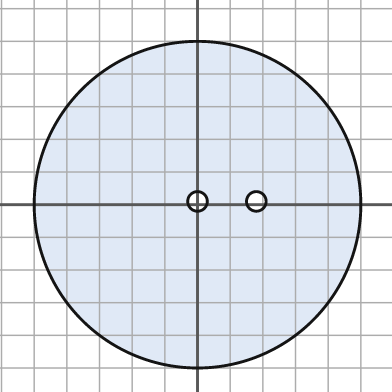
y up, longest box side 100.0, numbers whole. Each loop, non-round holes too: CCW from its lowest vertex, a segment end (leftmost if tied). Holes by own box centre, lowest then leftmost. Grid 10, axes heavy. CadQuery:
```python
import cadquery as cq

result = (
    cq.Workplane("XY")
    .moveTo(0.0, 0.0)
    .circle(50.0)
    .moveTo(0.0, 1.0)
    .circle(3.0)
    .moveTo(18.0, 1.0)
    .circle(3.0)
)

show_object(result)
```